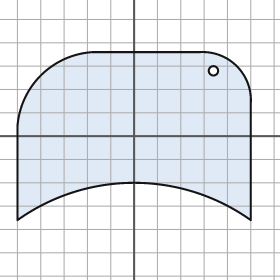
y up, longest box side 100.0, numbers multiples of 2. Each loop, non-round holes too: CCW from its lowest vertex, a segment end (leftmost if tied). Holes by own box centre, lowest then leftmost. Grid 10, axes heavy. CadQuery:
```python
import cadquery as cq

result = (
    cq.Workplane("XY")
    .moveTo(-50.0, -36.0)
    .threePointArc((0.0, -20.0), (50.0, -36.0))
    .lineTo(50.0, 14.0)
    .threePointArc((44.0, 30.0), (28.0, 36.0))
    .lineTo(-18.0, 36.0)
    .threePointArc((-40.0, 26.0), (-50.0, 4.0))
    .close()
    .moveTo(34.0, 28.0)
    .circle(2.0)
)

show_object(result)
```